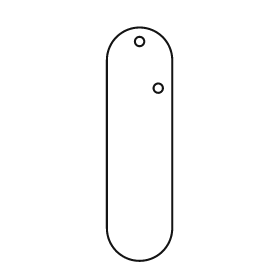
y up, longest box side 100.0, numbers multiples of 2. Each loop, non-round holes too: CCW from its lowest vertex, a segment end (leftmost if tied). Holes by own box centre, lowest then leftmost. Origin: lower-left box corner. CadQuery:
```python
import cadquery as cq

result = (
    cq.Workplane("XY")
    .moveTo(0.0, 14.0)
    .threePointArc((14.0, 0.0), (28.0, 14.0))
    .lineTo(28.0, 86.0)
    .threePointArc((14.0, 100.0), (0.0, 86.0))
    .close()
    .moveTo(22.0, 74.0)
    .circle(2.0)
    .moveTo(14.0, 94.0)
    .circle(2.0)
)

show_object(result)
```